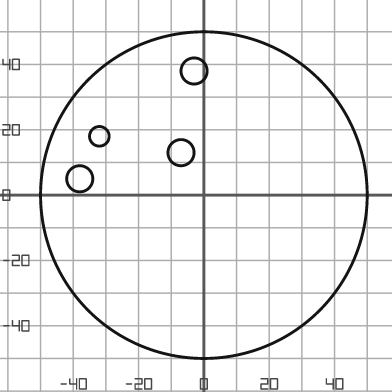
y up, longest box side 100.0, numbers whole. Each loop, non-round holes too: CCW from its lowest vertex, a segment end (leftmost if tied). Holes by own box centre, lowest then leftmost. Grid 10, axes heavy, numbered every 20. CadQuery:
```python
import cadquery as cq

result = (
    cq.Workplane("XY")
    .moveTo(0.0, 0.0)
    .circle(50.0)
    .moveTo(-38.0, 5.0)
    .circle(4.0)
    .moveTo(-7.0, 13.0)
    .circle(4.0)
    .moveTo(-32.0, 18.0)
    .circle(3.0)
    .moveTo(-3.0, 38.0)
    .circle(4.0)
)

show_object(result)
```